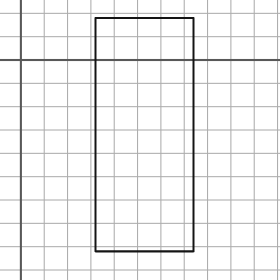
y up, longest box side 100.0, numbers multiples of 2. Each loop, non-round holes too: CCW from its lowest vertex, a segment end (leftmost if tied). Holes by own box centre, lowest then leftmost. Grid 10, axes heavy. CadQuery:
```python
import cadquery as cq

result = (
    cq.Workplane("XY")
    .moveTo(32.0, -82.0)
    .lineTo(74.0, -82.0)
    .lineTo(74.0, 18.0)
    .lineTo(32.0, 18.0)
    .close()
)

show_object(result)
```